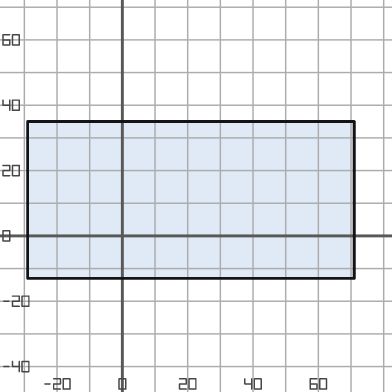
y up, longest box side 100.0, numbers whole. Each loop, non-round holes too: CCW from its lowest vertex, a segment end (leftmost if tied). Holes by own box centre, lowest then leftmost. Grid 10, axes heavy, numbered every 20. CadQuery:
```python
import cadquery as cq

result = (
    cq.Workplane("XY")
    .moveTo(-29.0, -13.0)
    .lineTo(71.0, -13.0)
    .lineTo(71.0, 35.0)
    .lineTo(-29.0, 35.0)
    .close()
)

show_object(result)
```